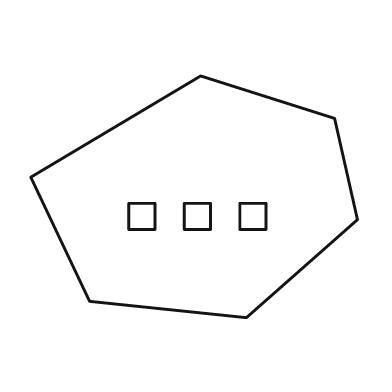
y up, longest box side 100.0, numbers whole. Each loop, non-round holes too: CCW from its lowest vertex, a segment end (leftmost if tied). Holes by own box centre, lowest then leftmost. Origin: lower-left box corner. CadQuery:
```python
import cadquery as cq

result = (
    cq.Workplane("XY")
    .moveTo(66.0, 0.0)
    .lineTo(100.0, 30.0)
    .lineTo(93.0, 61.0)
    .lineTo(52.0, 74.0)
    .lineTo(0.0, 43.0)
    .lineTo(18.0, 5.0)
    .close()
    .moveTo(30.0, 27.0)
    .lineTo(38.0, 27.0)
    .lineTo(38.0, 35.0)
    .lineTo(30.0, 35.0)
    .close()
    .moveTo(47.0, 27.0)
    .lineTo(55.0, 27.0)
    .lineTo(55.0, 35.0)
    .lineTo(47.0, 35.0)
    .close()
    .moveTo(64.0, 27.0)
    .lineTo(72.0, 27.0)
    .lineTo(72.0, 35.0)
    .lineTo(64.0, 35.0)
    .close()
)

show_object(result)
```